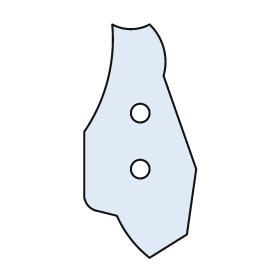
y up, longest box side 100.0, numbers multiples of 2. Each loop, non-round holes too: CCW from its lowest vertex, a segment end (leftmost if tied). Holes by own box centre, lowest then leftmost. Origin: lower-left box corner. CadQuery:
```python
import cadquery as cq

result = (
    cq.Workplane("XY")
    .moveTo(28.0, 0.0)
    .lineTo(44.0, 10.0)
    .lineTo(48.0, 38.0)
    .lineTo(34.0, 78.0)
    .threePointArc((34.0, 90.0), (28.0, 100.0))
    .threePointArc((20.0, 98.0), (12.0, 100.0))
    .threePointArc((10.0, 76.0), (0.0, 54.0))
    .lineTo(0.0, 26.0)
    .threePointArc((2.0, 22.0), (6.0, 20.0))
    .lineTo(14.0, 18.0)
    .threePointArc((20.0, 8.0), (28.0, 0.0))
    .close()
    .moveTo(24.0, 38.0)
    .circle(4.0)
    .moveTo(24.0, 62.0)
    .circle(4.0)
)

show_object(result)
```